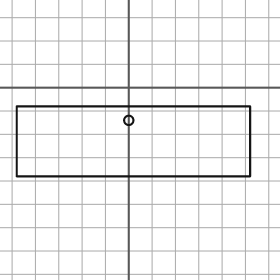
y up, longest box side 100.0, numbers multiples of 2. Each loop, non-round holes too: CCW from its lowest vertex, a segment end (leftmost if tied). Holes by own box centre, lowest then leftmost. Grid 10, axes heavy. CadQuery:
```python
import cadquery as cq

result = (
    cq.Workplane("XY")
    .moveTo(-48.0, -38.0)
    .lineTo(52.0, -38.0)
    .lineTo(52.0, -8.0)
    .lineTo(-48.0, -8.0)
    .close()
    .moveTo(0.0, -14.0)
    .circle(2.0)
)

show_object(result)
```